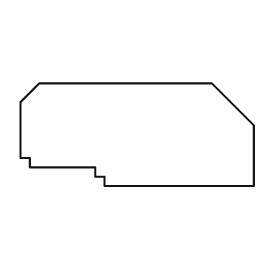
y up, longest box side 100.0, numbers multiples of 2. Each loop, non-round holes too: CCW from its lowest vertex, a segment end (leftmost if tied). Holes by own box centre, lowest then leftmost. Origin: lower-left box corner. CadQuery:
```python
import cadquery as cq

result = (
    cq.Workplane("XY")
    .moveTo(36.0, 0.0)
    .lineTo(100.0, 0.0)
    .lineTo(100.0, 26.0)
    .lineTo(82.0, 44.0)
    .lineTo(8.0, 44.0)
    .lineTo(0.0, 36.0)
    .lineTo(0.0, 12.0)
    .lineTo(4.0, 12.0)
    .lineTo(4.0, 8.0)
    .lineTo(32.0, 8.0)
    .lineTo(32.0, 4.0)
    .lineTo(36.0, 4.0)
    .close()
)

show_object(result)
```